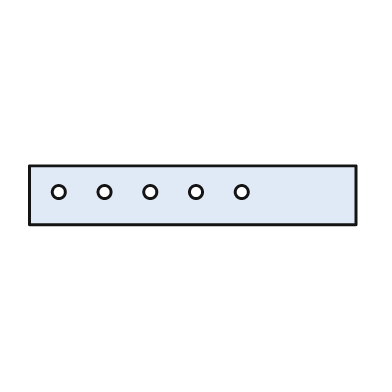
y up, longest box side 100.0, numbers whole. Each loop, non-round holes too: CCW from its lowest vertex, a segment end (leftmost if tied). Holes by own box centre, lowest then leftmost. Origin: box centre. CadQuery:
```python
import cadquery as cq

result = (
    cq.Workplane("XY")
    .moveTo(-50.0, -9.0)
    .lineTo(50.0, -9.0)
    .lineTo(50.0, 9.0)
    .lineTo(-50.0, 9.0)
    .close()
    .moveTo(-41.0, 1.0)
    .circle(2.0)
    .moveTo(-27.0, 1.0)
    .circle(2.0)
    .moveTo(-13.0, 1.0)
    .circle(2.0)
    .moveTo(1.0, 1.0)
    .circle(2.0)
    .moveTo(15.0, 1.0)
    .circle(2.0)
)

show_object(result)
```